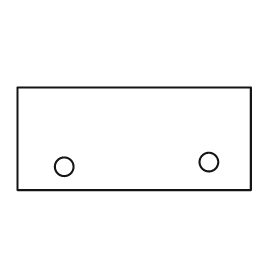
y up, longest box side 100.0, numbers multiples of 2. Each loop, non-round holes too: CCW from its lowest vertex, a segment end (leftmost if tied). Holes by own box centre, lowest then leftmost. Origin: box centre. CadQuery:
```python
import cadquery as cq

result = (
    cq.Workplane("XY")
    .moveTo(-50.0, -22.0)
    .lineTo(50.0, -22.0)
    .lineTo(50.0, 22.0)
    .lineTo(-50.0, 22.0)
    .close()
    .moveTo(-30.0, -12.0)
    .circle(4.0)
    .moveTo(32.0, -10.0)
    .circle(4.0)
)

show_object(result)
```